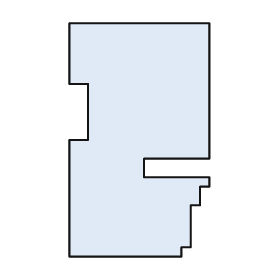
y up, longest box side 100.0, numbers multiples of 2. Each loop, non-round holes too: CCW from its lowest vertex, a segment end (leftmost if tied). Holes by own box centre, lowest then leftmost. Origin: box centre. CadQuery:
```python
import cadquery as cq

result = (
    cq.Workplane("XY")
    .moveTo(-30.0, -50.0)
    .lineTo(18.0, -50.0)
    .lineTo(18.0, -46.0)
    .lineTo(22.0, -46.0)
    .lineTo(22.0, -28.0)
    .lineTo(26.0, -28.0)
    .lineTo(26.0, -20.0)
    .lineTo(30.0, -20.0)
    .lineTo(30.0, -16.0)
    .lineTo(2.0, -16.0)
    .lineTo(2.0, -8.0)
    .lineTo(30.0, -8.0)
    .lineTo(30.0, 50.0)
    .lineTo(-30.0, 50.0)
    .lineTo(-30.0, 24.0)
    .lineTo(-22.0, 24.0)
    .lineTo(-22.0, 0.0)
    .lineTo(-30.0, 0.0)
    .close()
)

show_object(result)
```